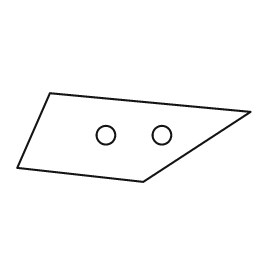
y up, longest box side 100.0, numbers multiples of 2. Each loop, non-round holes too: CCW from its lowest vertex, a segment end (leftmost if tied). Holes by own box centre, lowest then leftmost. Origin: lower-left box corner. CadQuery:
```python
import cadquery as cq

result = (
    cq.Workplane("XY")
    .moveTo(54.0, 0.0)
    .lineTo(100.0, 30.0)
    .lineTo(14.0, 38.0)
    .lineTo(0.0, 6.0)
    .close()
    .moveTo(38.0, 20.0)
    .circle(4.0)
    .moveTo(62.0, 20.0)
    .circle(4.0)
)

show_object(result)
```